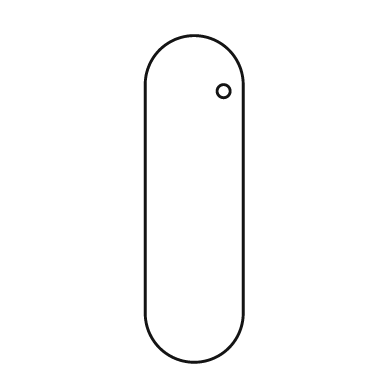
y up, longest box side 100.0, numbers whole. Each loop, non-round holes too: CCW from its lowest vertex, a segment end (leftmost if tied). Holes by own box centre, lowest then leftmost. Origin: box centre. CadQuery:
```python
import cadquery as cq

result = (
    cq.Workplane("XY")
    .moveTo(-15.0, -35.0)
    .threePointArc((0.0, -50.0), (15.0, -35.0))
    .lineTo(15.0, 35.0)
    .threePointArc((0.0, 50.0), (-15.0, 35.0))
    .close()
    .moveTo(9.0, 33.0)
    .circle(2.0)
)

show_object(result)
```